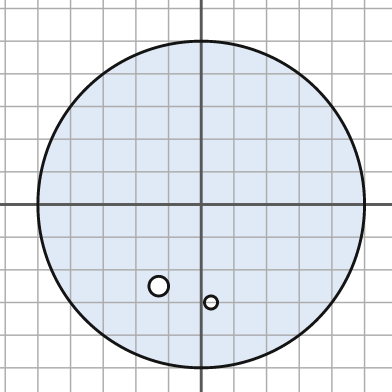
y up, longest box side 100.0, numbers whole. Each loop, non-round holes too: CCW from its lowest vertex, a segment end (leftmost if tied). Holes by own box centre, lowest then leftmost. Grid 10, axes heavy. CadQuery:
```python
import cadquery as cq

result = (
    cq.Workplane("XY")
    .moveTo(0.0, 0.0)
    .circle(50.0)
    .moveTo(3.0, -30.0)
    .circle(2.0)
    .moveTo(-13.0, -25.0)
    .circle(3.0)
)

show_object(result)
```